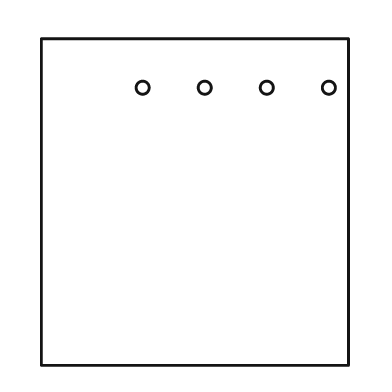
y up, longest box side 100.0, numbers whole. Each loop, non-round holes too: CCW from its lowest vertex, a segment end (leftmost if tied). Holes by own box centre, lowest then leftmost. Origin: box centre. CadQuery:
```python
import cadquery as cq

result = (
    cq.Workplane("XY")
    .moveTo(-47.0, -50.0)
    .lineTo(47.0, -50.0)
    .lineTo(47.0, 50.0)
    .lineTo(-47.0, 50.0)
    .close()
    .moveTo(-16.0, 35.0)
    .circle(2.0)
    .moveTo(3.0, 35.0)
    .circle(2.0)
    .moveTo(22.0, 35.0)
    .circle(2.0)
    .moveTo(41.0, 35.0)
    .circle(2.0)
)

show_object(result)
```